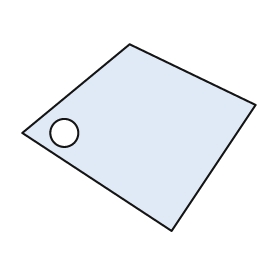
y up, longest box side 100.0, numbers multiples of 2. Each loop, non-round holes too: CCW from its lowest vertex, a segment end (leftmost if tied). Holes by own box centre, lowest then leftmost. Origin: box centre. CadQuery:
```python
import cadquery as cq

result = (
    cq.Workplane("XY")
    .moveTo(14.0, -40.0)
    .lineTo(50.0, 14.0)
    .lineTo(-4.0, 40.0)
    .lineTo(-50.0, 2.0)
    .close()
    .moveTo(-32.0, 2.0)
    .circle(6.0)
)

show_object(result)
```